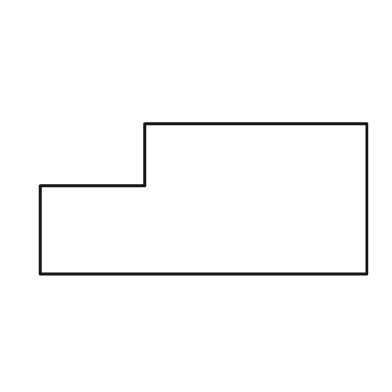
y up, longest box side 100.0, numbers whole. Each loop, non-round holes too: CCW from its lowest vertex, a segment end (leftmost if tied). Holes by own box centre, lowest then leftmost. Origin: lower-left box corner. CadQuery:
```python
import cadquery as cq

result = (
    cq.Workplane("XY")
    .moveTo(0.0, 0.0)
    .lineTo(100.0, 0.0)
    .lineTo(100.0, 46.0)
    .lineTo(32.0, 46.0)
    .lineTo(32.0, 27.0)
    .lineTo(0.0, 27.0)
    .close()
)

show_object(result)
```